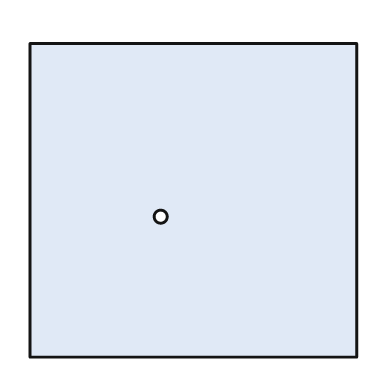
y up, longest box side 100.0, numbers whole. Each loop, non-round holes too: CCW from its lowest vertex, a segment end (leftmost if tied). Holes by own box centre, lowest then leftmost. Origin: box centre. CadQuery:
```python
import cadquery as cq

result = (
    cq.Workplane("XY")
    .moveTo(-50.0, -48.0)
    .lineTo(50.0, -48.0)
    .lineTo(50.0, 48.0)
    .lineTo(-50.0, 48.0)
    .close()
    .moveTo(-10.0, -5.0)
    .circle(2.0)
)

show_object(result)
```